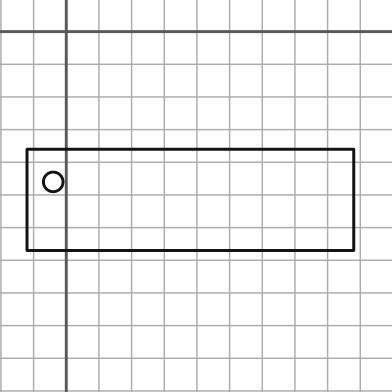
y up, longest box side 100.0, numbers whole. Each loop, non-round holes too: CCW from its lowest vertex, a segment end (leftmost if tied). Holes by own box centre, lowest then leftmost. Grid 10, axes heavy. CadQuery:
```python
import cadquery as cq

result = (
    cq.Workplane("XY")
    .moveTo(-12.0, -67.0)
    .lineTo(88.0, -67.0)
    .lineTo(88.0, -36.0)
    .lineTo(-12.0, -36.0)
    .close()
    .moveTo(-4.0, -46.0)
    .circle(3.0)
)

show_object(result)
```